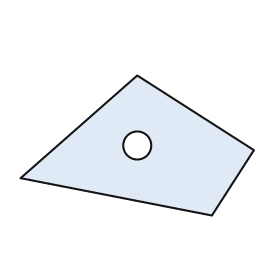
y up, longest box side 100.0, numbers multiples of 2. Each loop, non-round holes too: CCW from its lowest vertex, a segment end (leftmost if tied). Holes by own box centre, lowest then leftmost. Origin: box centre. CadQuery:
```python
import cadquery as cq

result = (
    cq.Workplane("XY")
    .moveTo(32.0, -30.0)
    .lineTo(50.0, -2.0)
    .lineTo(0.0, 30.0)
    .lineTo(-50.0, -14.0)
    .close()
    .moveTo(0.0, 0.0)
    .circle(6.0)
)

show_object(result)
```